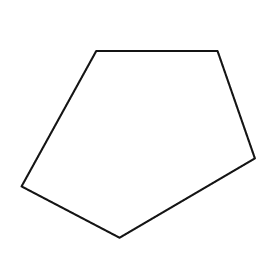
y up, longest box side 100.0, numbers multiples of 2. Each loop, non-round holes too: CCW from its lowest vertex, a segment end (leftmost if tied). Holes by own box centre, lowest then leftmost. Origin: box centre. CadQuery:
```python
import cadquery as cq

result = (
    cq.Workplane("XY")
    .moveTo(-8.0, -40.0)
    .lineTo(50.0, -6.0)
    .lineTo(34.0, 40.0)
    .lineTo(-18.0, 40.0)
    .lineTo(-50.0, -18.0)
    .close()
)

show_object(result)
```